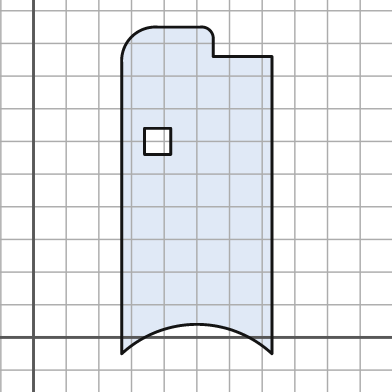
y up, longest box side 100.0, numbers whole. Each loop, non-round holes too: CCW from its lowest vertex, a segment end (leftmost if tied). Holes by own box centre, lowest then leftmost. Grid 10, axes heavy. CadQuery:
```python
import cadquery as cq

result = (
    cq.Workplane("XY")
    .moveTo(27.0, -5.0)
    .threePointArc((50.0, 4.0), (73.0, -5.0))
    .lineTo(73.0, 86.0)
    .lineTo(55.0, 86.0)
    .lineTo(55.0, 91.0)
    .threePointArc((54.0, 94.0), (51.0, 95.0))
    .lineTo(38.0, 95.0)
    .threePointArc((30.0, 92.0), (27.0, 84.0))
    .close()
    .moveTo(34.0, 56.0)
    .lineTo(42.0, 56.0)
    .lineTo(42.0, 64.0)
    .lineTo(34.0, 64.0)
    .close()
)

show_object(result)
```